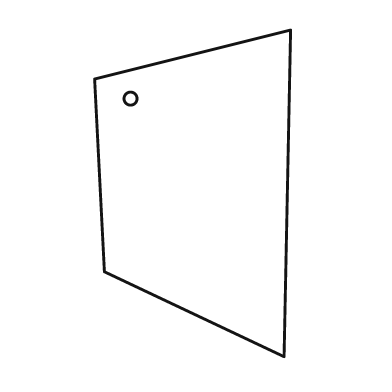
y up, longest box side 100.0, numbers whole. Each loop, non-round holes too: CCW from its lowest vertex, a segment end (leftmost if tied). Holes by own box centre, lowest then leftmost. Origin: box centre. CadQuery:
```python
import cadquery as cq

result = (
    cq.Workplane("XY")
    .moveTo(28.0, -50.0)
    .lineTo(30.0, 50.0)
    .lineTo(-30.0, 35.0)
    .lineTo(-27.0, -24.0)
    .close()
    .moveTo(-19.0, 29.0)
    .circle(2.0)
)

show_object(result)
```